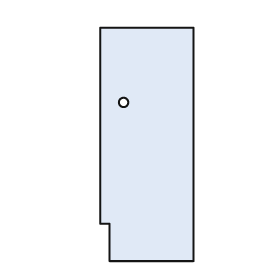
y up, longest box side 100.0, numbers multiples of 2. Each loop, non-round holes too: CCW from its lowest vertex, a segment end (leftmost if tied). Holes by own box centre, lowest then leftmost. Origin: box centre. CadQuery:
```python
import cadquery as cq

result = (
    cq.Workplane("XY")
    .moveTo(-16.0, -50.0)
    .lineTo(20.0, -50.0)
    .lineTo(20.0, 50.0)
    .lineTo(-20.0, 50.0)
    .lineTo(-20.0, -34.0)
    .lineTo(-16.0, -34.0)
    .close()
    .moveTo(-10.0, 18.0)
    .circle(2.0)
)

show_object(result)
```